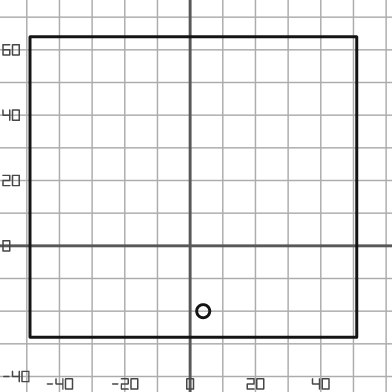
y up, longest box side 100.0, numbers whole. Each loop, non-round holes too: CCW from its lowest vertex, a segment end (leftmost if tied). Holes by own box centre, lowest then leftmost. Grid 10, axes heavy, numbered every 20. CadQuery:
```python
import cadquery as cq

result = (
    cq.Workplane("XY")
    .moveTo(-49.0, -28.0)
    .lineTo(51.0, -28.0)
    .lineTo(51.0, 64.0)
    .lineTo(-49.0, 64.0)
    .close()
    .moveTo(4.0, -20.0)
    .circle(2.0)
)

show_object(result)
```